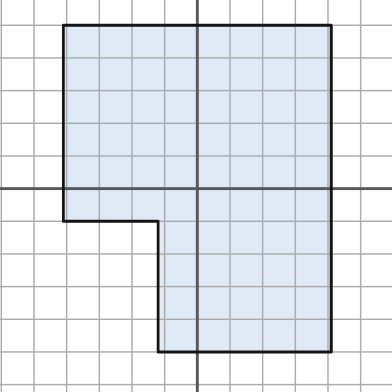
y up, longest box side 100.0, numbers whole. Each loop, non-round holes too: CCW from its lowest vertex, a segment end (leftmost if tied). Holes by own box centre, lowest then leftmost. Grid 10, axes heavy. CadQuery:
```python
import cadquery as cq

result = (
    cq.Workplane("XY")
    .moveTo(-12.0, -50.0)
    .lineTo(41.0, -50.0)
    .lineTo(41.0, 50.0)
    .lineTo(-41.0, 50.0)
    .lineTo(-41.0, -10.0)
    .lineTo(-12.0, -10.0)
    .close()
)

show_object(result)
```